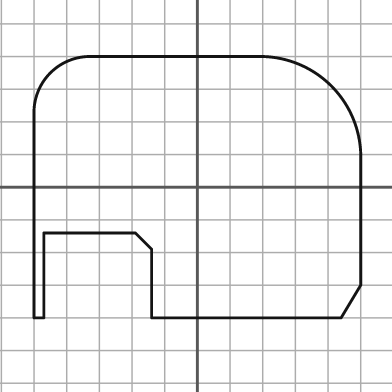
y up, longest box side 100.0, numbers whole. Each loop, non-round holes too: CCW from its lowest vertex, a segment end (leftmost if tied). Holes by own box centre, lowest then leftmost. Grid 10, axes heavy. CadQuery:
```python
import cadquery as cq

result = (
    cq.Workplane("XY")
    .moveTo(-50.0, -40.0)
    .lineTo(-47.0, -40.0)
    .lineTo(-47.0, -14.0)
    .lineTo(-19.0, -14.0)
    .lineTo(-14.0, -19.0)
    .lineTo(-14.0, -40.0)
    .lineTo(44.0, -40.0)
    .lineTo(50.0, -30.0)
    .lineTo(50.0, 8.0)
    .threePointArc((41.0, 31.0), (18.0, 40.0))
    .lineTo(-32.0, 40.0)
    .threePointArc((-45.0, 35.0), (-50.0, 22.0))
    .close()
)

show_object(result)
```